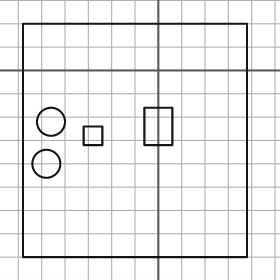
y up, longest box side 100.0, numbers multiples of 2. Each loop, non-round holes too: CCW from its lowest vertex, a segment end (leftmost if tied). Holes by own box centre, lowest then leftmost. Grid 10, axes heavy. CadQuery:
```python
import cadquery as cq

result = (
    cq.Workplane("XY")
    .moveTo(-58.0, -80.0)
    .lineTo(38.0, -80.0)
    .lineTo(38.0, 20.0)
    .lineTo(-58.0, 20.0)
    .close()
    .moveTo(-48.0, -40.0)
    .circle(6.0)
    .moveTo(-32.0, -32.0)
    .lineTo(-24.0, -32.0)
    .lineTo(-24.0, -24.0)
    .lineTo(-32.0, -24.0)
    .close()
    .moveTo(-6.0, -32.0)
    .lineTo(6.0, -32.0)
    .lineTo(6.0, -16.0)
    .lineTo(-6.0, -16.0)
    .close()
    .moveTo(-46.0, -22.0)
    .circle(6.0)
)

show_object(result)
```